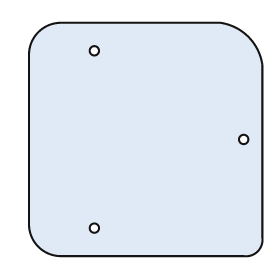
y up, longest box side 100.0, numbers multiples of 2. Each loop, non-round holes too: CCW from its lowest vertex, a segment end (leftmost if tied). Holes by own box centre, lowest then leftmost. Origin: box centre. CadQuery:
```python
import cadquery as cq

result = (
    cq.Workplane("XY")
    .moveTo(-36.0, -50.0)
    .lineTo(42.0, -50.0)
    .threePointArc((48.0, -48.0), (50.0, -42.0))
    .lineTo(50.0, 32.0)
    .threePointArc((44.0, 44.0), (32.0, 50.0))
    .lineTo(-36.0, 50.0)
    .threePointArc((-46.0, 46.0), (-50.0, 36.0))
    .lineTo(-50.0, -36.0)
    .threePointArc((-46.0, -46.0), (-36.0, -50.0))
    .close()
    .moveTo(-22.0, -38.0)
    .circle(2.0)
    .moveTo(42.0, 0.0)
    .circle(2.0)
    .moveTo(-22.0, 38.0)
    .circle(2.0)
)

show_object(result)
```